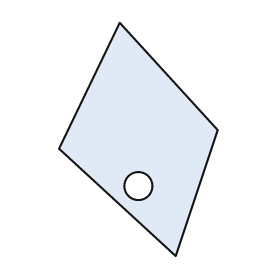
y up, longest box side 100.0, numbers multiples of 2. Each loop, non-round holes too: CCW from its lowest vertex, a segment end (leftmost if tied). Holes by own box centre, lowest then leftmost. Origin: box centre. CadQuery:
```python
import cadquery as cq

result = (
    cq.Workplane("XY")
    .moveTo(16.0, -50.0)
    .lineTo(34.0, 4.0)
    .lineTo(-8.0, 50.0)
    .lineTo(-34.0, -4.0)
    .close()
    .moveTo(0.0, -20.0)
    .circle(6.0)
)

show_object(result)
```